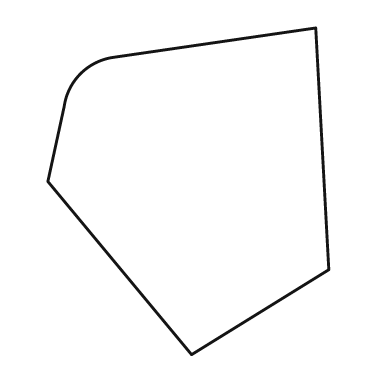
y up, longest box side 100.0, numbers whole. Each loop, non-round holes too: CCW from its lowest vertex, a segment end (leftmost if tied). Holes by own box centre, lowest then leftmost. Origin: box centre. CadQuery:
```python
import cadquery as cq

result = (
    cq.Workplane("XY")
    .moveTo(1.0, -50.0)
    .lineTo(43.0, -24.0)
    .lineTo(39.0, 50.0)
    .lineTo(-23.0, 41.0)
    .threePointArc((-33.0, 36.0), (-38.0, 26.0))
    .lineTo(-43.0, 3.0)
    .close()
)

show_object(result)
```